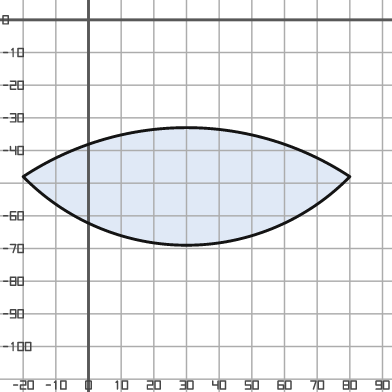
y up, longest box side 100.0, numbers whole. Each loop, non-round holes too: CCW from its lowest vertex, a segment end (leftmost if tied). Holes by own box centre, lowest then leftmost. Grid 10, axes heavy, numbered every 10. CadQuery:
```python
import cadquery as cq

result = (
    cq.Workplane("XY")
    .moveTo(-20.0, -48.0)
    .threePointArc((30.0, -69.0), (80.0, -48.0))
    .threePointArc((30.0, -33.0), (-20.0, -48.0))
    .close()
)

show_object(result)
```